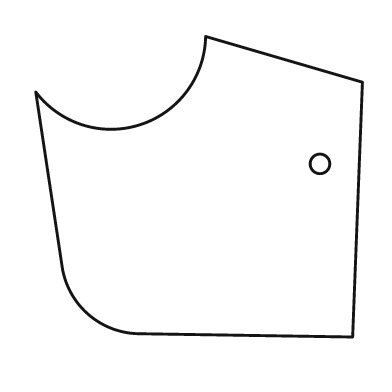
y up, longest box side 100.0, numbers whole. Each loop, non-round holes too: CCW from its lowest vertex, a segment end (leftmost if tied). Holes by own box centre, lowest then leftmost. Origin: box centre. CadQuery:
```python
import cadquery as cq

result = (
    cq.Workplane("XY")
    .moveTo(47.0, -46.0)
    .lineTo(50.0, 32.0)
    .lineTo(2.0, 46.0)
    .threePointArc((-18.0, 19.0), (-50.0, 29.0))
    .lineTo(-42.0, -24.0)
    .threePointArc((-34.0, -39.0), (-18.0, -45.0))
    .close()
    .moveTo(37.0, 7.0)
    .circle(3.0)
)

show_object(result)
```